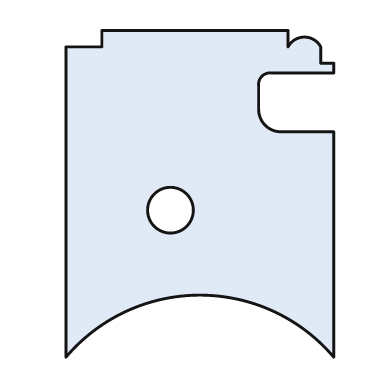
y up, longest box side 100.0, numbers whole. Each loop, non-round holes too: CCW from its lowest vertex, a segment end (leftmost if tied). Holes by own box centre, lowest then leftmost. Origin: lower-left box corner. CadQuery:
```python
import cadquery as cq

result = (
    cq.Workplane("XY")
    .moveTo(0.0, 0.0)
    .threePointArc((41.0, 19.0), (82.0, 0.0))
    .lineTo(82.0, 69.0)
    .lineTo(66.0, 69.0)
    .threePointArc((61.0, 71.0), (59.0, 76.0))
    .lineTo(59.0, 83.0)
    .threePointArc((60.0, 86.0), (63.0, 87.0))
    .lineTo(82.0, 87.0)
    .lineTo(82.0, 90.0)
    .lineTo(78.0, 90.0)
    .lineTo(78.0, 95.0)
    .threePointArc((73.0, 98.0), (68.0, 95.0))
    .lineTo(68.0, 100.0)
    .lineTo(11.0, 100.0)
    .lineTo(11.0, 95.0)
    .lineTo(0.0, 95.0)
    .close()
    .moveTo(32.0, 45.0)
    .circle(7.0)
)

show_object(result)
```